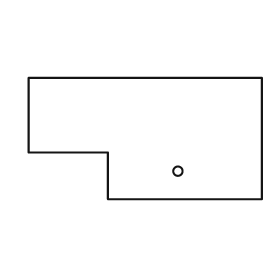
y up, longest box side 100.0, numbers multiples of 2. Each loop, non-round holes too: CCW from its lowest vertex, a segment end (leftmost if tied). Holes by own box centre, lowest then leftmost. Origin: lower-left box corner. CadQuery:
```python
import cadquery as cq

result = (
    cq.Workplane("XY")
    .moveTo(34.0, 0.0)
    .lineTo(100.0, 0.0)
    .lineTo(100.0, 52.0)
    .lineTo(0.0, 52.0)
    .lineTo(0.0, 20.0)
    .lineTo(34.0, 20.0)
    .close()
    .moveTo(64.0, 12.0)
    .circle(2.0)
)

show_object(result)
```